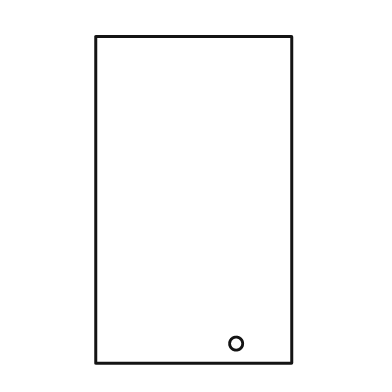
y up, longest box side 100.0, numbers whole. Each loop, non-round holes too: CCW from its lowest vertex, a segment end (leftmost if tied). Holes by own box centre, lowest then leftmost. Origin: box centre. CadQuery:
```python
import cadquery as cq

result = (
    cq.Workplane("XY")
    .moveTo(-30.0, -50.0)
    .lineTo(30.0, -50.0)
    .lineTo(30.0, 50.0)
    .lineTo(-30.0, 50.0)
    .close()
    .moveTo(13.0, -44.0)
    .circle(2.0)
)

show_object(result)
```